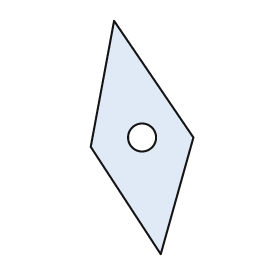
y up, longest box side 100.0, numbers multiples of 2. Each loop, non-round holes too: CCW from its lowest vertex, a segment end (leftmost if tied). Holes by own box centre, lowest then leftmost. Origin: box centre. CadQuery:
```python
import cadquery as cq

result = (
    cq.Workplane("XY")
    .moveTo(8.0, -50.0)
    .lineTo(22.0, 0.0)
    .lineTo(-12.0, 50.0)
    .lineTo(-22.0, -4.0)
    .close()
    .moveTo(0.0, 0.0)
    .circle(6.0)
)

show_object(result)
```